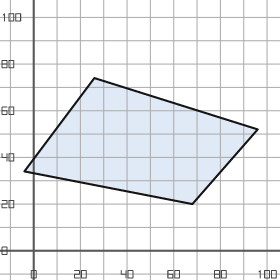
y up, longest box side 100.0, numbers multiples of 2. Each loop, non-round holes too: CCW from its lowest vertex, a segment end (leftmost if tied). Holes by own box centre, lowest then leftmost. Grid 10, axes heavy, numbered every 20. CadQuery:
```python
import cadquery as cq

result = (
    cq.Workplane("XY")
    .moveTo(68.0, 20.0)
    .lineTo(96.0, 52.0)
    .lineTo(26.0, 74.0)
    .lineTo(-4.0, 34.0)
    .close()
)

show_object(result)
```